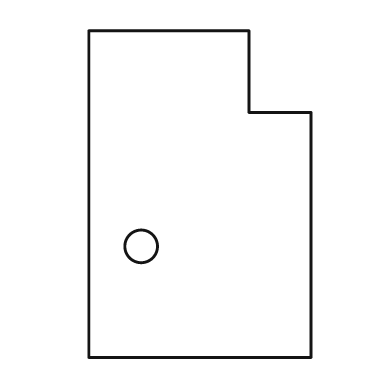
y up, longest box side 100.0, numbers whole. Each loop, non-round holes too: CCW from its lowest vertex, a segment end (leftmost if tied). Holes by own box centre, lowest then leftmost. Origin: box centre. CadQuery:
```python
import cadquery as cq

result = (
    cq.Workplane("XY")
    .moveTo(-34.0, -50.0)
    .lineTo(34.0, -50.0)
    .lineTo(34.0, 25.0)
    .lineTo(15.0, 25.0)
    .lineTo(15.0, 50.0)
    .lineTo(-34.0, 50.0)
    .close()
    .moveTo(-18.0, -16.0)
    .circle(5.0)
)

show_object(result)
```